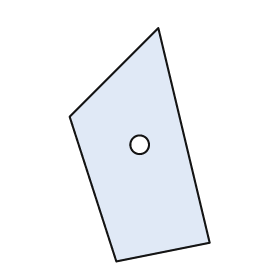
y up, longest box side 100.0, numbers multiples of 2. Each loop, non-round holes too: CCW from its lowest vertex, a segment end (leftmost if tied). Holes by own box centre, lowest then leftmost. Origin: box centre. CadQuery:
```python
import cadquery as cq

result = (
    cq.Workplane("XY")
    .moveTo(-10.0, -50.0)
    .lineTo(30.0, -42.0)
    .lineTo(8.0, 50.0)
    .lineTo(-30.0, 12.0)
    .close()
    .moveTo(0.0, 0.0)
    .circle(4.0)
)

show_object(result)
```